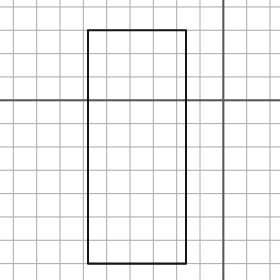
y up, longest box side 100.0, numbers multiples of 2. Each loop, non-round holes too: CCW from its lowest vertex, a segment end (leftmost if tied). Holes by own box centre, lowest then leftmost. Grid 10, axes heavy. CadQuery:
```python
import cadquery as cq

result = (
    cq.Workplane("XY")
    .moveTo(-58.0, -70.0)
    .lineTo(-16.0, -70.0)
    .lineTo(-16.0, 30.0)
    .lineTo(-58.0, 30.0)
    .close()
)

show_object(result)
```